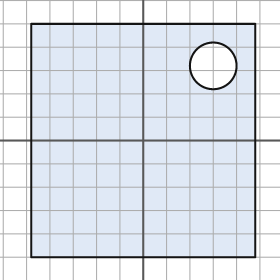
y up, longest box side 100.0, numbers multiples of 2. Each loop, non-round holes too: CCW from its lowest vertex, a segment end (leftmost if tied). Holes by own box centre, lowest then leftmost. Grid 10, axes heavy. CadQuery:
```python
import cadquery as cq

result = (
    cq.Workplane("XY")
    .moveTo(-48.0, -50.0)
    .lineTo(48.0, -50.0)
    .lineTo(48.0, 50.0)
    .lineTo(-48.0, 50.0)
    .close()
    .moveTo(30.0, 32.0)
    .circle(10.0)
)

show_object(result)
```